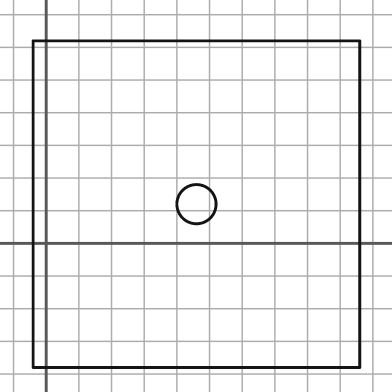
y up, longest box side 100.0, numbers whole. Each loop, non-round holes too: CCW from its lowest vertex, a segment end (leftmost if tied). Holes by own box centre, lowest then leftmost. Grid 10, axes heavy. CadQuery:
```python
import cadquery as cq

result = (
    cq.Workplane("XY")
    .moveTo(-4.0, -38.0)
    .lineTo(96.0, -38.0)
    .lineTo(96.0, 62.0)
    .lineTo(-4.0, 62.0)
    .close()
    .moveTo(46.0, 12.0)
    .circle(6.0)
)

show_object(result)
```